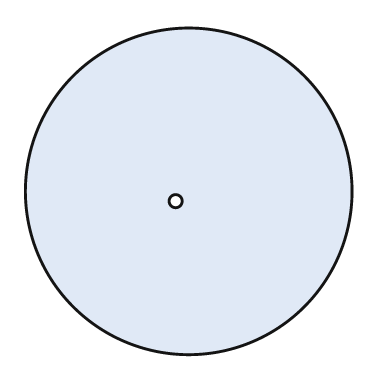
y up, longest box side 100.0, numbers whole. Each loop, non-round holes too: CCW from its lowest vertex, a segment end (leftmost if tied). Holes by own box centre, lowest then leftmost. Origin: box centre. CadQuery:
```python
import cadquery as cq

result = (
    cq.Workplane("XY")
    .moveTo(0.0, 0.0)
    .circle(50.0)
    .moveTo(-4.0, -3.0)
    .circle(2.0)
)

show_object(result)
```